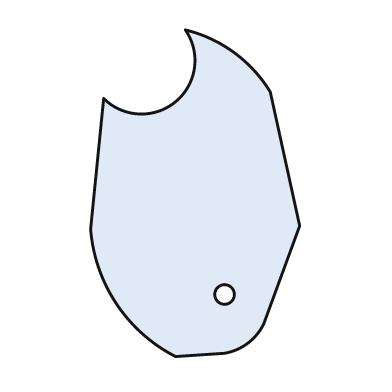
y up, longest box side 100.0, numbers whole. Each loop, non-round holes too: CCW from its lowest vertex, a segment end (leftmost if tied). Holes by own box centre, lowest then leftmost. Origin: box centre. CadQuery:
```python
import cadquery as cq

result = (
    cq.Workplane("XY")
    .moveTo(-6.0, -50.0)
    .lineTo(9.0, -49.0)
    .threePointArc((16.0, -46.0), (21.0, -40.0))
    .lineTo(32.0, -10.0)
    .lineTo(23.0, 31.0)
    .threePointArc((12.0, 43.0), (-3.0, 50.0))
    .threePointArc((-6.0, 28.0), (-28.0, 29.0))
    .lineTo(-32.0, -11.0)
    .threePointArc((-24.0, -34.0), (-6.0, -50.0))
    .close()
    .moveTo(9.0, -31.0)
    .circle(3.0)
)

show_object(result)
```